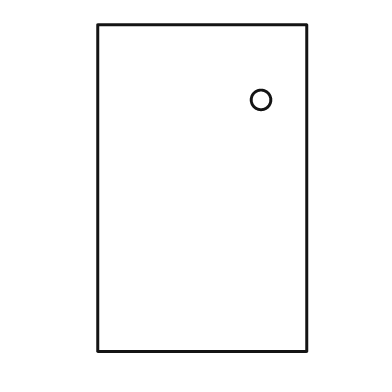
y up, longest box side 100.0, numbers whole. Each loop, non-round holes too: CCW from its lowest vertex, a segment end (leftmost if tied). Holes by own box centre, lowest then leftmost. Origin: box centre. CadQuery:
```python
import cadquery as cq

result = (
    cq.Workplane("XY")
    .moveTo(-32.0, -50.0)
    .lineTo(32.0, -50.0)
    .lineTo(32.0, 50.0)
    .lineTo(-32.0, 50.0)
    .close()
    .moveTo(18.0, 27.0)
    .circle(3.0)
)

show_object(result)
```